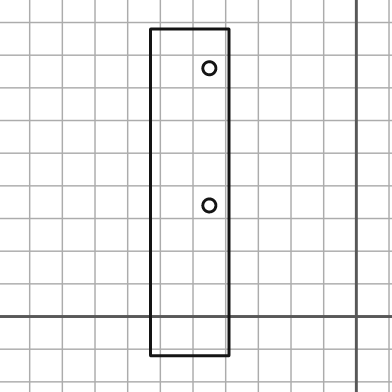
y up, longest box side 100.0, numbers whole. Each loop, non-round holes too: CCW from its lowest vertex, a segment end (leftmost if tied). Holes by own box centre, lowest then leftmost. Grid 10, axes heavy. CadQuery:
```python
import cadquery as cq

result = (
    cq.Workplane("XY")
    .moveTo(-63.0, -12.0)
    .lineTo(-39.0, -12.0)
    .lineTo(-39.0, 88.0)
    .lineTo(-63.0, 88.0)
    .close()
    .moveTo(-45.0, 34.0)
    .circle(2.0)
    .moveTo(-45.0, 76.0)
    .circle(2.0)
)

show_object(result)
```